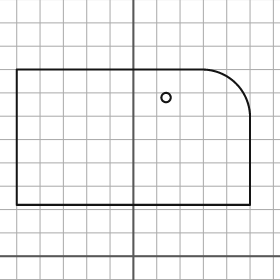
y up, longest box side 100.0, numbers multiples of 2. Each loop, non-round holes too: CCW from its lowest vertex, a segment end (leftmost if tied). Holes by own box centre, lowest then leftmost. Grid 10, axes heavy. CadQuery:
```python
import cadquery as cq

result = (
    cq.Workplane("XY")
    .moveTo(-50.0, 22.0)
    .lineTo(50.0, 22.0)
    .lineTo(50.0, 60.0)
    .threePointArc((44.0, 74.0), (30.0, 80.0))
    .lineTo(-50.0, 80.0)
    .close()
    .moveTo(14.0, 68.0)
    .circle(2.0)
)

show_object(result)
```